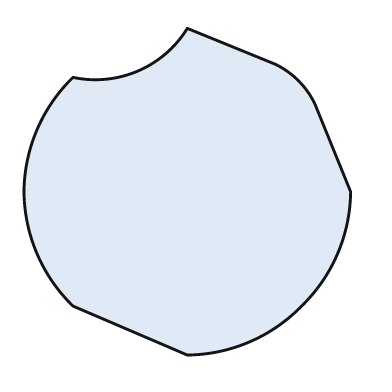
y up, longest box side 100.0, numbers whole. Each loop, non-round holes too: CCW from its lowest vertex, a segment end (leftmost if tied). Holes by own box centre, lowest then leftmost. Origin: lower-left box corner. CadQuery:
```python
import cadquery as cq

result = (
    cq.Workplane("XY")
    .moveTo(50.0, 0.0)
    .threePointArc((69.0, 4.0), (85.0, 15.0))
    .threePointArc((96.0, 31.0), (100.0, 50.0))
    .lineTo(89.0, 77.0)
    .threePointArc((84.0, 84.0), (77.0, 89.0))
    .lineTo(50.0, 100.0)
    .threePointArc((35.0, 87.0), (15.0, 85.0))
    .threePointArc((4.0, 69.0), (0.0, 50.0))
    .threePointArc((4.0, 31.0), (15.0, 15.0))
    .close()
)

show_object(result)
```